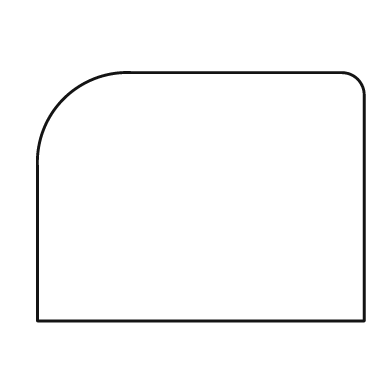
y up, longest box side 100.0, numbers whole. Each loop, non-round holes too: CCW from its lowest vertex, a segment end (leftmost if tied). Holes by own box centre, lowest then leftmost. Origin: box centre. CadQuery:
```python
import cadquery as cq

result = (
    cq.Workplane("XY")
    .moveTo(-50.0, -38.0)
    .lineTo(50.0, -38.0)
    .lineTo(50.0, 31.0)
    .threePointArc((48.0, 36.0), (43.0, 38.0))
    .lineTo(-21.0, 38.0)
    .threePointArc((-42.0, 30.0), (-50.0, 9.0))
    .close()
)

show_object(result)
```